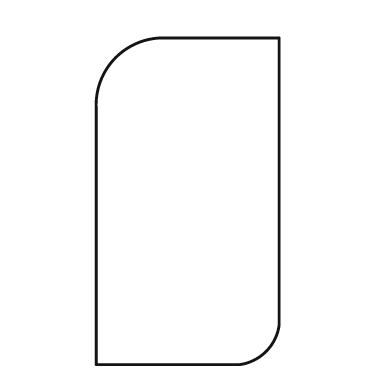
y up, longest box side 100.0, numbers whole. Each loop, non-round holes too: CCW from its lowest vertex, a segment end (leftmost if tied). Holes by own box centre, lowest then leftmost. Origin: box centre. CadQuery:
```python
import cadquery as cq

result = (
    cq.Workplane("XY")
    .moveTo(-28.0, -50.0)
    .lineTo(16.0, -50.0)
    .threePointArc((24.0, -46.0), (28.0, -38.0))
    .lineTo(28.0, 50.0)
    .lineTo(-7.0, 50.0)
    .threePointArc((-22.0, 44.0), (-28.0, 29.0))
    .close()
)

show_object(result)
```